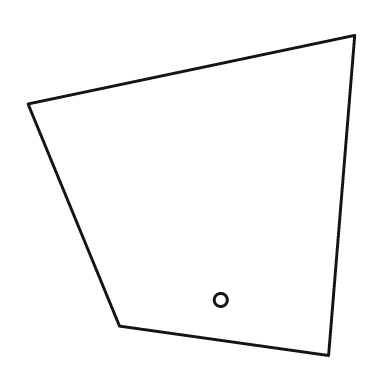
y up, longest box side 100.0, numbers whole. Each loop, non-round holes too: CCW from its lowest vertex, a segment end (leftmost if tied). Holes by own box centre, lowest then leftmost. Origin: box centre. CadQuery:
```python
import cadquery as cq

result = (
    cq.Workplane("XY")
    .moveTo(42.0, -49.0)
    .lineTo(50.0, 49.0)
    .lineTo(-50.0, 28.0)
    .lineTo(-22.0, -40.0)
    .close()
    .moveTo(9.0, -32.0)
    .circle(2.0)
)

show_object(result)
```